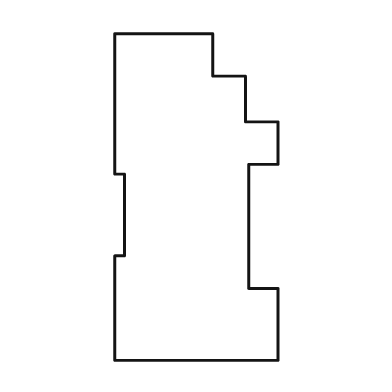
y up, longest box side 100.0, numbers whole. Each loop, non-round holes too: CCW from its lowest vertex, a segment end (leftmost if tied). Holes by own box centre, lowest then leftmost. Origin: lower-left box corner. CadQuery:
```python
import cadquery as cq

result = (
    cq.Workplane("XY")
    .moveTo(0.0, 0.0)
    .lineTo(50.0, 0.0)
    .lineTo(50.0, 22.0)
    .lineTo(41.0, 22.0)
    .lineTo(41.0, 60.0)
    .lineTo(50.0, 60.0)
    .lineTo(50.0, 73.0)
    .lineTo(40.0, 73.0)
    .lineTo(40.0, 87.0)
    .lineTo(30.0, 87.0)
    .lineTo(30.0, 100.0)
    .lineTo(0.0, 100.0)
    .lineTo(0.0, 57.0)
    .lineTo(3.0, 57.0)
    .lineTo(3.0, 32.0)
    .lineTo(0.0, 32.0)
    .close()
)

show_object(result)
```